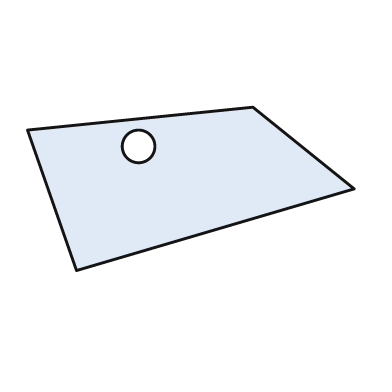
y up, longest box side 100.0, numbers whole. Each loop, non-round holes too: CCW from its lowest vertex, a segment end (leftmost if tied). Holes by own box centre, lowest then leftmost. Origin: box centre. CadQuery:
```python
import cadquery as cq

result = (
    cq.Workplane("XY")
    .moveTo(-35.0, -25.0)
    .lineTo(50.0, 0.0)
    .lineTo(19.0, 25.0)
    .lineTo(-50.0, 18.0)
    .close()
    .moveTo(-16.0, 13.0)
    .circle(5.0)
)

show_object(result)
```